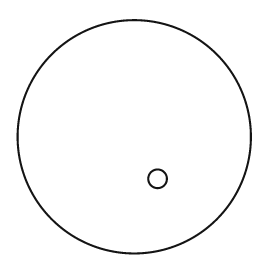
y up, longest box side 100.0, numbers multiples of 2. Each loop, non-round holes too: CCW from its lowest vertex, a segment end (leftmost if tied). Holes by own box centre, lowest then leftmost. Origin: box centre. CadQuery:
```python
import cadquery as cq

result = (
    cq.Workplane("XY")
    .moveTo(0.0, 0.0)
    .circle(50.0)
    .moveTo(10.0, -18.0)
    .circle(4.0)
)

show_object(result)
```